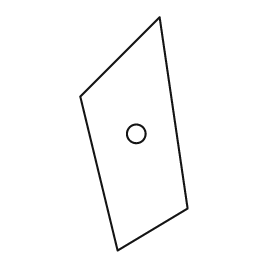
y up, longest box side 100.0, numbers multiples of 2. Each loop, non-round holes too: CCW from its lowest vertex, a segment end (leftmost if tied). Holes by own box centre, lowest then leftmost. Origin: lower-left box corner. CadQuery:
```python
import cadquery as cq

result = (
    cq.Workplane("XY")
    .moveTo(16.0, 0.0)
    .lineTo(46.0, 18.0)
    .lineTo(34.0, 100.0)
    .lineTo(0.0, 66.0)
    .close()
    .moveTo(24.0, 50.0)
    .circle(4.0)
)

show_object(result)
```